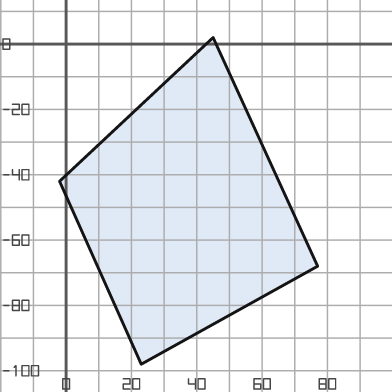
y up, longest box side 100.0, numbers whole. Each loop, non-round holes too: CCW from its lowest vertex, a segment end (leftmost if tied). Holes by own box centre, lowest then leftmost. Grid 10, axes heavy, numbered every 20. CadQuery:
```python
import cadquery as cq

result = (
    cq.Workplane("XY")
    .moveTo(23.0, -98.0)
    .lineTo(77.0, -68.0)
    .lineTo(45.0, 2.0)
    .lineTo(-2.0, -42.0)
    .close()
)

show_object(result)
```